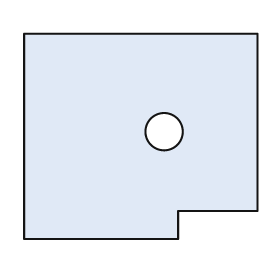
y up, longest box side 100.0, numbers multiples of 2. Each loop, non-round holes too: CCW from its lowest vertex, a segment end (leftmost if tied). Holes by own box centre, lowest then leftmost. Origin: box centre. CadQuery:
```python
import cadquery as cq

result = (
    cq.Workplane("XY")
    .moveTo(-50.0, -44.0)
    .lineTo(16.0, -44.0)
    .lineTo(16.0, -32.0)
    .lineTo(50.0, -32.0)
    .lineTo(50.0, 44.0)
    .lineTo(-50.0, 44.0)
    .close()
    .moveTo(10.0, 2.0)
    .circle(8.0)
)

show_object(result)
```